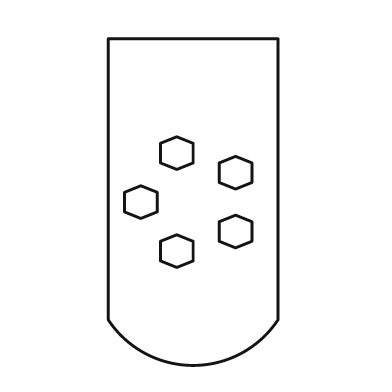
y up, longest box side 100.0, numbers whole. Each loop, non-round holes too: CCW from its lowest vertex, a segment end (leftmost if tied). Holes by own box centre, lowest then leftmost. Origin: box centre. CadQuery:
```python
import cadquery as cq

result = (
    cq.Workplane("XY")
    .moveTo(-26.0, -36.0)
    .threePointArc((0.0, -50.0), (26.0, -36.0))
    .lineTo(26.0, 50.0)
    .lineTo(-26.0, 50.0)
    .close()
    .moveTo(-5.0, -20.0)
    .lineTo(0.0, -18.0)
    .lineTo(0.0, -12.0)
    .lineTo(-5.0, -10.0)
    .lineTo(-10.0, -12.0)
    .lineTo(-10.0, -18.0)
    .close()
    .moveTo(13.0, -14.0)
    .lineTo(18.0, -12.0)
    .lineTo(18.0, -6.0)
    .lineTo(13.0, -4.0)
    .lineTo(8.0, -6.0)
    .lineTo(8.0, -12.0)
    .close()
    .moveTo(-16.0, -5.0)
    .lineTo(-11.0, -3.0)
    .lineTo(-11.0, 3.0)
    .lineTo(-16.0, 5.0)
    .lineTo(-21.0, 3.0)
    .lineTo(-21.0, -3.0)
    .close()
    .moveTo(13.0, 4.0)
    .lineTo(18.0, 6.0)
    .lineTo(18.0, 12.0)
    .lineTo(13.0, 14.0)
    .lineTo(8.0, 12.0)
    .lineTo(8.0, 6.0)
    .close()
    .moveTo(-5.0, 10.0)
    .lineTo(0.0, 12.0)
    .lineTo(0.0, 18.0)
    .lineTo(-5.0, 20.0)
    .lineTo(-10.0, 18.0)
    .lineTo(-10.0, 12.0)
    .close()
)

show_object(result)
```